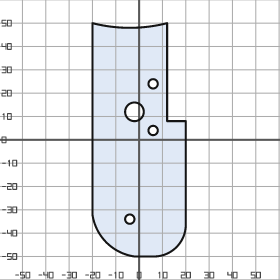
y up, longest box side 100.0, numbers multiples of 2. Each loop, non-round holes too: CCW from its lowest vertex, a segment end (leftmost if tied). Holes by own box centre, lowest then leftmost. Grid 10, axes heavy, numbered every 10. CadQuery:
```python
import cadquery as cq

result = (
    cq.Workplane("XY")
    .moveTo(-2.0, -50.0)
    .lineTo(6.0, -50.0)
    .threePointArc((16.0, -46.0), (20.0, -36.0))
    .lineTo(20.0, 8.0)
    .lineTo(12.0, 8.0)
    .lineTo(12.0, 50.0)
    .threePointArc((-4.0, 48.0), (-20.0, 50.0))
    .lineTo(-20.0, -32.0)
    .threePointArc((-14.0, -44.0), (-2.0, -50.0))
    .close()
    .moveTo(-4.0, -34.0)
    .circle(2.0)
    .moveTo(6.0, 4.0)
    .circle(2.0)
    .moveTo(-2.0, 12.0)
    .circle(4.0)
    .moveTo(6.0, 24.0)
    .circle(2.0)
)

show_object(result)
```